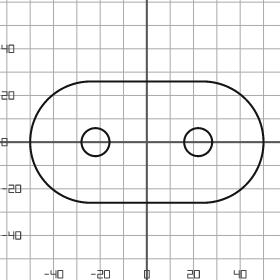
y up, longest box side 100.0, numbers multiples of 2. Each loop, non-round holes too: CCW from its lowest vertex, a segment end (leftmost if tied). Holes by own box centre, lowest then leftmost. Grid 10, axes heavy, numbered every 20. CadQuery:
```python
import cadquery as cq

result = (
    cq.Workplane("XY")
    .moveTo(-24.0, -26.0)
    .lineTo(24.0, -26.0)
    .threePointArc((50.0, 0.0), (24.0, 26.0))
    .lineTo(-24.0, 26.0)
    .threePointArc((-50.0, 0.0), (-24.0, -26.0))
    .close()
    .moveTo(-22.0, 0.0)
    .circle(6.0)
    .moveTo(22.0, 0.0)
    .circle(6.0)
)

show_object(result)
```